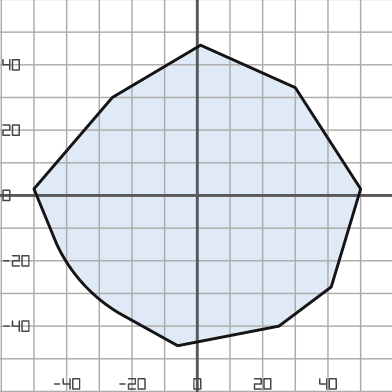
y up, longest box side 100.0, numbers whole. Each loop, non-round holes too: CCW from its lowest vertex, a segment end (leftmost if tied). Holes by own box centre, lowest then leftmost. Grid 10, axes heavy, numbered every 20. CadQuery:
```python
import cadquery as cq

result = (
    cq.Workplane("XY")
    .moveTo(-6.0, -46.0)
    .lineTo(25.0, -40.0)
    .lineTo(41.0, -28.0)
    .lineTo(50.0, 2.0)
    .lineTo(30.0, 33.0)
    .lineTo(1.0, 46.0)
    .lineTo(-26.0, 30.0)
    .lineTo(-50.0, 2.0)
    .lineTo(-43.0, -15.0)
    .threePointArc((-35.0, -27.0), (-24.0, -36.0))
    .close()
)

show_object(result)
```